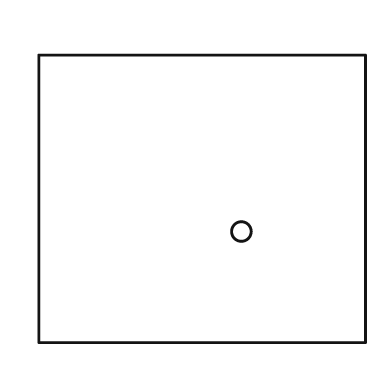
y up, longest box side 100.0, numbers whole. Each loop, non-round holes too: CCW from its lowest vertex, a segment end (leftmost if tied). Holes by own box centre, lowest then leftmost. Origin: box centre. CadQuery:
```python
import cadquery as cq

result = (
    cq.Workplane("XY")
    .moveTo(-50.0, -44.0)
    .lineTo(50.0, -44.0)
    .lineTo(50.0, 44.0)
    .lineTo(-50.0, 44.0)
    .close()
    .moveTo(12.0, -10.0)
    .circle(3.0)
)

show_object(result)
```